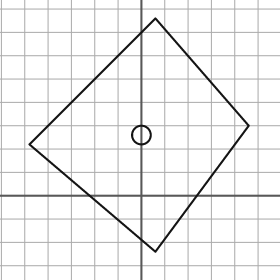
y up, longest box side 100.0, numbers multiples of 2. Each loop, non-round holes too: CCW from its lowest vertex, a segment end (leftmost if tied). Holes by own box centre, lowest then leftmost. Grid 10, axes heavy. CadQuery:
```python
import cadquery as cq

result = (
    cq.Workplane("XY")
    .moveTo(6.0, -24.0)
    .lineTo(46.0, 30.0)
    .lineTo(6.0, 76.0)
    .lineTo(-48.0, 22.0)
    .close()
    .moveTo(0.0, 26.0)
    .circle(4.0)
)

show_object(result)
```